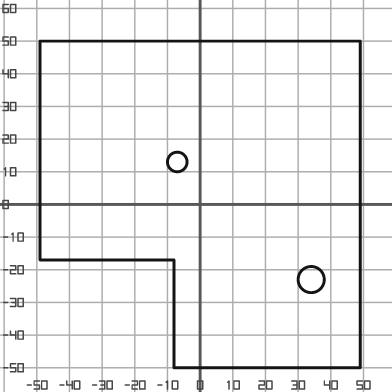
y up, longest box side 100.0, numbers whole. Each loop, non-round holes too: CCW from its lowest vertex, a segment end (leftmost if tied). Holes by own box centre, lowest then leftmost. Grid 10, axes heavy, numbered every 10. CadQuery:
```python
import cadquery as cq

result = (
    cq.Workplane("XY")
    .moveTo(-8.0, -50.0)
    .lineTo(49.0, -50.0)
    .lineTo(49.0, 50.0)
    .lineTo(-49.0, 50.0)
    .lineTo(-49.0, -17.0)
    .lineTo(-8.0, -17.0)
    .close()
    .moveTo(34.0, -23.0)
    .circle(4.0)
    .moveTo(-7.0, 13.0)
    .circle(3.0)
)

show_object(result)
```